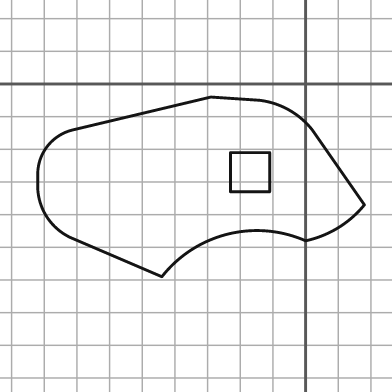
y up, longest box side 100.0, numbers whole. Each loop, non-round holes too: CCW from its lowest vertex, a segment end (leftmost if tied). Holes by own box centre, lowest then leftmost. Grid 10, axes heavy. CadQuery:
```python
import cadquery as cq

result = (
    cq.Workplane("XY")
    .moveTo(-44.0, -59.0)
    .threePointArc((-24.0, -46.0), (0.0, -48.0))
    .threePointArc((10.0, -44.0), (18.0, -37.0))
    .lineTo(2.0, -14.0)
    .threePointArc((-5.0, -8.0), (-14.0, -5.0))
    .lineTo(-29.0, -4.0)
    .lineTo(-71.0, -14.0)
    .threePointArc((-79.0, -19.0), (-82.0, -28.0))
    .lineTo(-82.0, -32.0)
    .threePointArc((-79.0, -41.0), (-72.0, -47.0))
    .close()
    .moveTo(-23.0, -33.0)
    .lineTo(-11.0, -33.0)
    .lineTo(-11.0, -21.0)
    .lineTo(-23.0, -21.0)
    .close()
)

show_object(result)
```